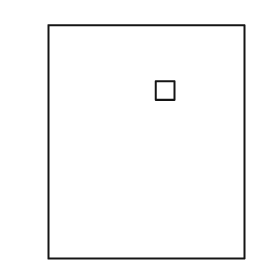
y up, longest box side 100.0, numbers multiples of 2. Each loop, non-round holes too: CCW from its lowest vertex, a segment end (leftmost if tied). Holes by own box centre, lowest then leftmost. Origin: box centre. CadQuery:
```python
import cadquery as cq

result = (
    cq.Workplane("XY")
    .moveTo(-42.0, -50.0)
    .lineTo(42.0, -50.0)
    .lineTo(42.0, 50.0)
    .lineTo(-42.0, 50.0)
    .close()
    .moveTo(4.0, 18.0)
    .lineTo(12.0, 18.0)
    .lineTo(12.0, 26.0)
    .lineTo(4.0, 26.0)
    .close()
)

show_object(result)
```